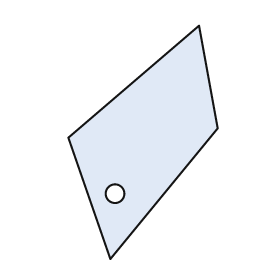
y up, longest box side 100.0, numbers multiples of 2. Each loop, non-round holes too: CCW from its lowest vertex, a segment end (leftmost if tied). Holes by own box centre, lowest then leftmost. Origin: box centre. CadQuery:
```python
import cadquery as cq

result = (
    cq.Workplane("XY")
    .moveTo(-14.0, -50.0)
    .lineTo(32.0, 6.0)
    .lineTo(24.0, 50.0)
    .lineTo(-32.0, 2.0)
    .close()
    .moveTo(-12.0, -22.0)
    .circle(4.0)
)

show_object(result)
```